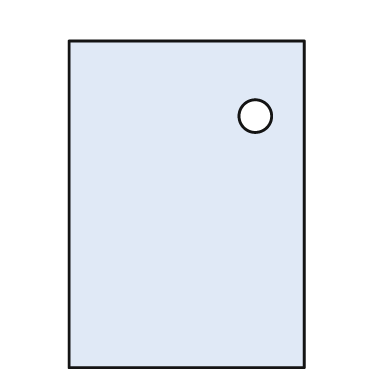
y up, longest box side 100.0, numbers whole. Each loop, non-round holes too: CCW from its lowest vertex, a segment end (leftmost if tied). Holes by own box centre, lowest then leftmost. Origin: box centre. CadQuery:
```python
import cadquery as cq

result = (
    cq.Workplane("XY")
    .moveTo(-36.0, -50.0)
    .lineTo(36.0, -50.0)
    .lineTo(36.0, 50.0)
    .lineTo(-36.0, 50.0)
    .close()
    .moveTo(21.0, 27.0)
    .circle(5.0)
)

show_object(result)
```